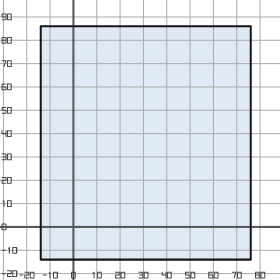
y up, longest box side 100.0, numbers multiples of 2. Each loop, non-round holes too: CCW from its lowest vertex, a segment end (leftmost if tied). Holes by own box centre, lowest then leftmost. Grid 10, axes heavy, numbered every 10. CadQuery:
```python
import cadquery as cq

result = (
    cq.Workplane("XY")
    .moveTo(-14.0, -14.0)
    .lineTo(76.0, -14.0)
    .lineTo(76.0, 86.0)
    .lineTo(-14.0, 86.0)
    .close()
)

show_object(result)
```